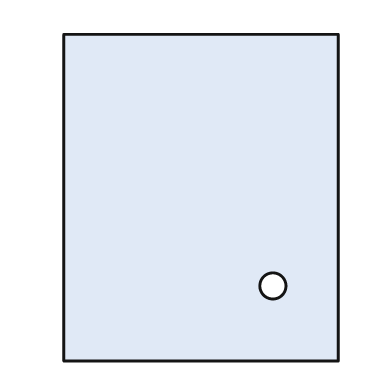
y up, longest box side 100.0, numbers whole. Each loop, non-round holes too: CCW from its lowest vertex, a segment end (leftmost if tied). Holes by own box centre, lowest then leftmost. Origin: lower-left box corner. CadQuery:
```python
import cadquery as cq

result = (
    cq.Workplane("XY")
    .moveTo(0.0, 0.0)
    .lineTo(84.0, 0.0)
    .lineTo(84.0, 100.0)
    .lineTo(0.0, 100.0)
    .close()
    .moveTo(64.0, 23.0)
    .circle(4.0)
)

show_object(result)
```